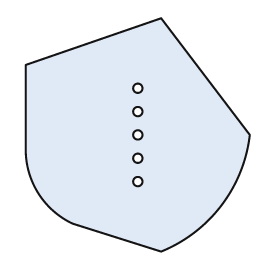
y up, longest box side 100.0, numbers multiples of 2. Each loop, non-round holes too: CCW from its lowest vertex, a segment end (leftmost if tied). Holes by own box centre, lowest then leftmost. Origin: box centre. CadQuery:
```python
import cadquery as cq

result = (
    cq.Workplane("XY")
    .moveTo(10.0, -50.0)
    .threePointArc((36.0, -30.0), (48.0, 0.0))
    .lineTo(10.0, 50.0)
    .lineTo(-48.0, 30.0)
    .lineTo(-48.0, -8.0)
    .threePointArc((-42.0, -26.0), (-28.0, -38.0))
    .close()
    .moveTo(0.0, -20.0)
    .circle(2.0)
    .moveTo(0.0, -10.0)
    .circle(2.0)
    .moveTo(0.0, 0.0)
    .circle(2.0)
    .moveTo(0.0, 10.0)
    .circle(2.0)
    .moveTo(0.0, 20.0)
    .circle(2.0)
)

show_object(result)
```